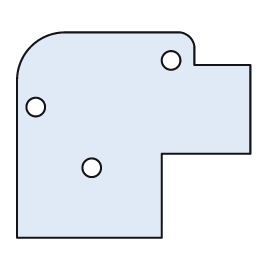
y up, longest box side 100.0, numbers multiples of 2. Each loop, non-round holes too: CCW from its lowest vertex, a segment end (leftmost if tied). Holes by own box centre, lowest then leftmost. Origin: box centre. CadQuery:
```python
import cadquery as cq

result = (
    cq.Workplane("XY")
    .moveTo(-50.0, -44.0)
    .lineTo(12.0, -44.0)
    .lineTo(12.0, -8.0)
    .lineTo(50.0, -8.0)
    .lineTo(50.0, 30.0)
    .lineTo(26.0, 30.0)
    .lineTo(26.0, 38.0)
    .threePointArc((24.0, 42.0), (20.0, 44.0))
    .lineTo(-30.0, 44.0)
    .threePointArc((-44.0, 38.0), (-50.0, 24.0))
    .close()
    .moveTo(-18.0, -14.0)
    .circle(4.0)
    .moveTo(-42.0, 12.0)
    .circle(4.0)
    .moveTo(16.0, 32.0)
    .circle(4.0)
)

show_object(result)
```